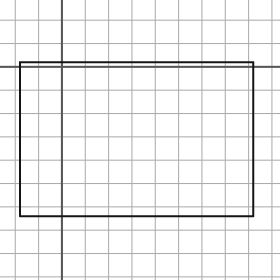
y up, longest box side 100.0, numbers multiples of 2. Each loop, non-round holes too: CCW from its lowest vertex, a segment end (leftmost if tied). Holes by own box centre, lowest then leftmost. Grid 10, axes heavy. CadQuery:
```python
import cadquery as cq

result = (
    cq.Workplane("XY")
    .moveTo(-18.0, -64.0)
    .lineTo(82.0, -64.0)
    .lineTo(82.0, 2.0)
    .lineTo(-18.0, 2.0)
    .close()
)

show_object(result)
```